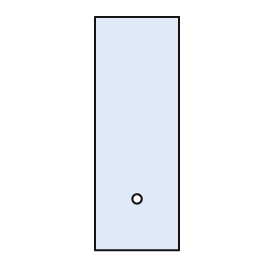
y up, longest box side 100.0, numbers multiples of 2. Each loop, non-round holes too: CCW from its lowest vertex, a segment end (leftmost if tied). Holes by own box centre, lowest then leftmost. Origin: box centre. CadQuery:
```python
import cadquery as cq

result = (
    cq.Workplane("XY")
    .moveTo(-18.0, -50.0)
    .lineTo(18.0, -50.0)
    .lineTo(18.0, 50.0)
    .lineTo(-18.0, 50.0)
    .close()
    .moveTo(0.0, -28.0)
    .circle(2.0)
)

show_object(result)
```